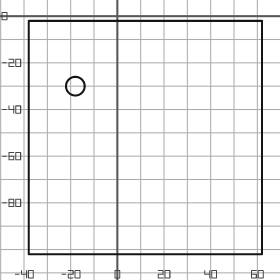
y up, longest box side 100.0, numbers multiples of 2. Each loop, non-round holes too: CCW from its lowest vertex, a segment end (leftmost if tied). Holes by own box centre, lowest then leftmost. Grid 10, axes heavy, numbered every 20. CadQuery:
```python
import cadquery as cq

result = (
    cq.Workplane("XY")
    .moveTo(-38.0, -102.0)
    .lineTo(62.0, -102.0)
    .lineTo(62.0, -2.0)
    .lineTo(-38.0, -2.0)
    .close()
    .moveTo(-18.0, -30.0)
    .circle(4.0)
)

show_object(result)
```